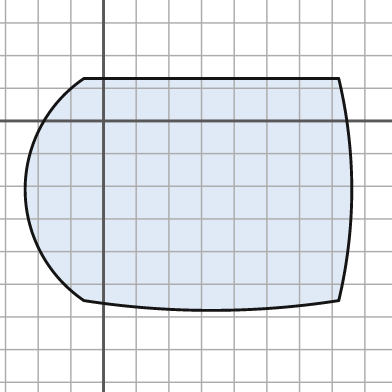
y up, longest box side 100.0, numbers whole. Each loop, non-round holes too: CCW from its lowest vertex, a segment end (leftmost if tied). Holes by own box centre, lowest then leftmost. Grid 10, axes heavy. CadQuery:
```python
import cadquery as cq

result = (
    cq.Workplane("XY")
    .moveTo(-6.0, -55.0)
    .threePointArc((33.0, -58.0), (72.0, -55.0))
    .threePointArc((76.0, -21.0), (72.0, 13.0))
    .lineTo(-6.0, 13.0)
    .threePointArc((-24.0, -21.0), (-6.0, -55.0))
    .close()
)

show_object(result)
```